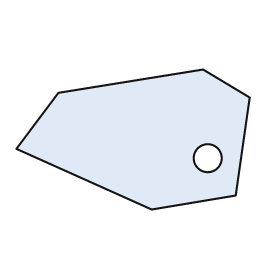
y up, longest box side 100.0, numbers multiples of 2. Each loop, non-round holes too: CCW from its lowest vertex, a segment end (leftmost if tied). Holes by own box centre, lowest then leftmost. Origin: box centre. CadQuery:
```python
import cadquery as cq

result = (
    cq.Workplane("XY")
    .moveTo(8.0, -30.0)
    .lineTo(44.0, -24.0)
    .lineTo(50.0, 18.0)
    .lineTo(30.0, 30.0)
    .lineTo(-32.0, 20.0)
    .lineTo(-50.0, -4.0)
    .close()
    .moveTo(32.0, -8.0)
    .circle(6.0)
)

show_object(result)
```